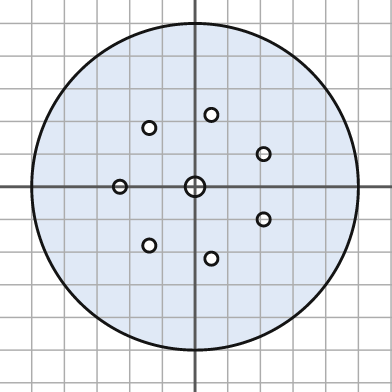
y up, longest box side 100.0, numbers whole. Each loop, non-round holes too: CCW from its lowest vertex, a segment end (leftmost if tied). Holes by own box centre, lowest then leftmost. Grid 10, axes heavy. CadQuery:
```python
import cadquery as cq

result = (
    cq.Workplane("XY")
    .moveTo(0.0, 0.0)
    .circle(50.0)
    .moveTo(5.0, -22.0)
    .circle(2.0)
    .moveTo(-14.0, -18.0)
    .circle(2.0)
    .moveTo(21.0, -10.0)
    .circle(2.0)
    .moveTo(-23.0, 0.0)
    .circle(2.0)
    .moveTo(0.0, 0.0)
    .circle(3.0)
    .moveTo(21.0, 10.0)
    .circle(2.0)
    .moveTo(-14.0, 18.0)
    .circle(2.0)
    .moveTo(5.0, 22.0)
    .circle(2.0)
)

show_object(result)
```